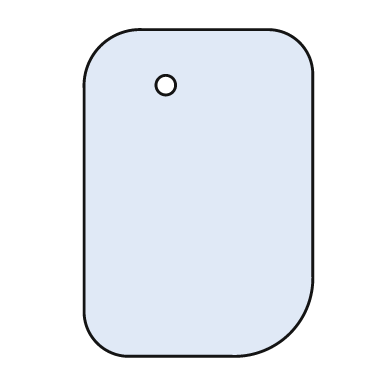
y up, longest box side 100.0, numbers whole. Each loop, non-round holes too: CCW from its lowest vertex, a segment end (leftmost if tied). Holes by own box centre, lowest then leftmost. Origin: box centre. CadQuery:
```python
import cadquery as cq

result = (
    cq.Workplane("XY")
    .moveTo(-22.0, -50.0)
    .lineTo(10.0, -50.0)
    .threePointArc((28.0, -43.0), (35.0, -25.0))
    .lineTo(35.0, 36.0)
    .threePointArc((31.0, 46.0), (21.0, 50.0))
    .lineTo(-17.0, 50.0)
    .threePointArc((-30.0, 45.0), (-35.0, 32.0))
    .lineTo(-35.0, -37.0)
    .threePointArc((-31.0, -46.0), (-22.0, -50.0))
    .close()
    .moveTo(-10.0, 33.0)
    .circle(3.0)
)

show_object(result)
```